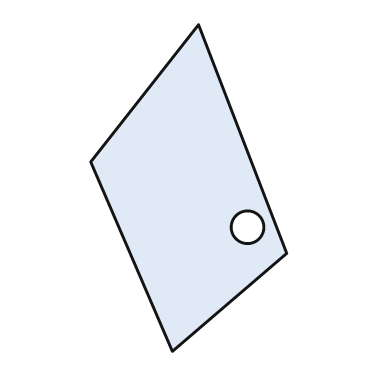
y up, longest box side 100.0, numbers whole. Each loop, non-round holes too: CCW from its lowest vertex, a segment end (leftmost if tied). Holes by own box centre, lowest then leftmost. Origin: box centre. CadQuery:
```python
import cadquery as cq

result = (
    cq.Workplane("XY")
    .moveTo(-5.0, -50.0)
    .lineTo(30.0, -20.0)
    .lineTo(3.0, 50.0)
    .lineTo(-30.0, 8.0)
    .close()
    .moveTo(18.0, -12.0)
    .circle(5.0)
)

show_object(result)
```